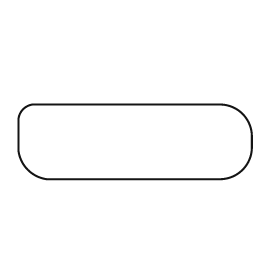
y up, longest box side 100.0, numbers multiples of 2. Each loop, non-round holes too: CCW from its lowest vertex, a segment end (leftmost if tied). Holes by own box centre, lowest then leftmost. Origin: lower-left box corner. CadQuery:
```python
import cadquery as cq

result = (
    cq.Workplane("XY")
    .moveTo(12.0, 0.0)
    .lineTo(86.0, 0.0)
    .threePointArc((96.0, 4.0), (100.0, 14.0))
    .lineTo(100.0, 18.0)
    .threePointArc((96.0, 28.0), (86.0, 32.0))
    .lineTo(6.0, 32.0)
    .threePointArc((2.0, 30.0), (0.0, 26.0))
    .lineTo(0.0, 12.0)
    .threePointArc((4.0, 4.0), (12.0, 0.0))
    .close()
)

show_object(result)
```